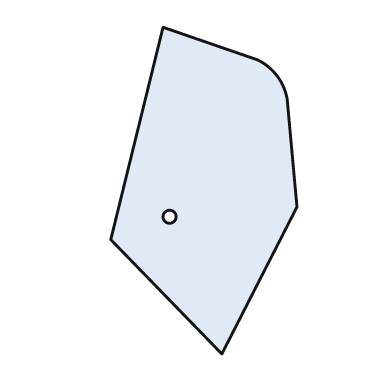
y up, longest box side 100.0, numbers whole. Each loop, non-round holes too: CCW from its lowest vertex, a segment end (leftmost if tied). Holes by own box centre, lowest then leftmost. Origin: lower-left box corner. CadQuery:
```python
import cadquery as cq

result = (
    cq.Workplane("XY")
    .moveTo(34.0, 0.0)
    .lineTo(57.0, 45.0)
    .lineTo(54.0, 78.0)
    .threePointArc((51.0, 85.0), (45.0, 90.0))
    .lineTo(16.0, 100.0)
    .lineTo(0.0, 35.0)
    .close()
    .moveTo(18.0, 42.0)
    .circle(2.0)
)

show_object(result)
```